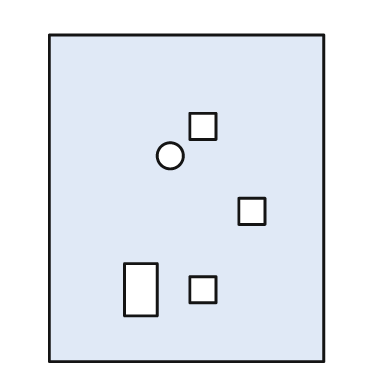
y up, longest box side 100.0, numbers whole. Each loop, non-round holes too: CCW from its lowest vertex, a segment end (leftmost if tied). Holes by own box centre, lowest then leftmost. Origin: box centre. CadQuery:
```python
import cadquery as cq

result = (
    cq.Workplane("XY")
    .moveTo(-42.0, -50.0)
    .lineTo(42.0, -50.0)
    .lineTo(42.0, 50.0)
    .lineTo(-42.0, 50.0)
    .close()
    .moveTo(-19.0, -36.0)
    .lineTo(-9.0, -36.0)
    .lineTo(-9.0, -20.0)
    .lineTo(-19.0, -20.0)
    .close()
    .moveTo(1.0, -32.0)
    .lineTo(9.0, -32.0)
    .lineTo(9.0, -24.0)
    .lineTo(1.0, -24.0)
    .close()
    .moveTo(16.0, -8.0)
    .lineTo(24.0, -8.0)
    .lineTo(24.0, 0.0)
    .lineTo(16.0, 0.0)
    .close()
    .moveTo(-5.0, 13.0)
    .circle(4.0)
    .moveTo(1.0, 18.0)
    .lineTo(9.0, 18.0)
    .lineTo(9.0, 26.0)
    .lineTo(1.0, 26.0)
    .close()
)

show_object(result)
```